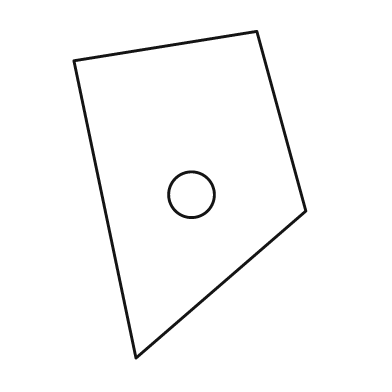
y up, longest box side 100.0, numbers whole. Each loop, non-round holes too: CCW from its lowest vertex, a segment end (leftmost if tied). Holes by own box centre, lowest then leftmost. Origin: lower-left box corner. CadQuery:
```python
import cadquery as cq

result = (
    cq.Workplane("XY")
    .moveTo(19.0, 0.0)
    .lineTo(71.0, 45.0)
    .lineTo(56.0, 100.0)
    .lineTo(0.0, 91.0)
    .close()
    .moveTo(36.0, 50.0)
    .circle(7.0)
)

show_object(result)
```